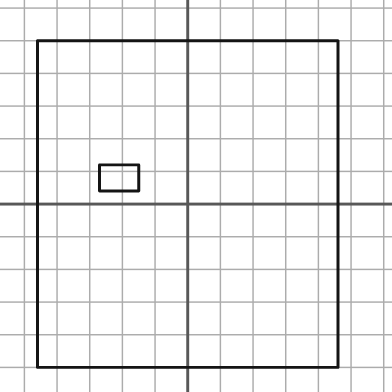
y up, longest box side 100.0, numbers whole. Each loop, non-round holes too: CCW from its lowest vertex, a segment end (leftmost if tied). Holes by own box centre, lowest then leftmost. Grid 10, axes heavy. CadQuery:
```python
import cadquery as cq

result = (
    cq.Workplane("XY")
    .moveTo(-46.0, -50.0)
    .lineTo(46.0, -50.0)
    .lineTo(46.0, 50.0)
    .lineTo(-46.0, 50.0)
    .close()
    .moveTo(-27.0, 4.0)
    .lineTo(-15.0, 4.0)
    .lineTo(-15.0, 12.0)
    .lineTo(-27.0, 12.0)
    .close()
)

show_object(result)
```